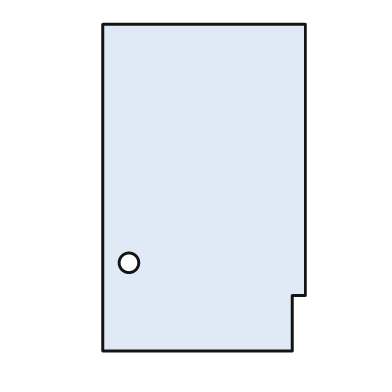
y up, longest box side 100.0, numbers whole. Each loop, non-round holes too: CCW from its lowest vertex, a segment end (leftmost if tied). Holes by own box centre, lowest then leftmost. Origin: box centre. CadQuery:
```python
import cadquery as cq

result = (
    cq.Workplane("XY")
    .moveTo(-31.0, -50.0)
    .lineTo(27.0, -50.0)
    .lineTo(27.0, -33.0)
    .lineTo(31.0, -33.0)
    .lineTo(31.0, 50.0)
    .lineTo(-31.0, 50.0)
    .close()
    .moveTo(-23.0, -23.0)
    .circle(3.0)
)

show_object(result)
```